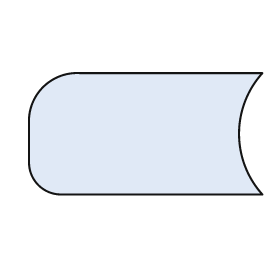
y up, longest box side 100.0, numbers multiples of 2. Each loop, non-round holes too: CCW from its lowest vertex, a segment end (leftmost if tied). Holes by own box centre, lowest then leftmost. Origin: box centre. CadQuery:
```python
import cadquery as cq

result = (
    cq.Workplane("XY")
    .moveTo(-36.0, -26.0)
    .lineTo(50.0, -26.0)
    .threePointArc((40.0, 0.0), (50.0, 26.0))
    .lineTo(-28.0, 26.0)
    .threePointArc((-44.0, 20.0), (-50.0, 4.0))
    .lineTo(-50.0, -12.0)
    .threePointArc((-46.0, -22.0), (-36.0, -26.0))
    .close()
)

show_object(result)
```